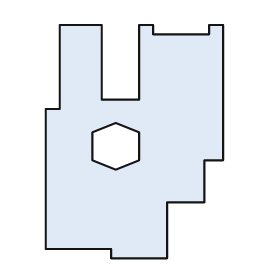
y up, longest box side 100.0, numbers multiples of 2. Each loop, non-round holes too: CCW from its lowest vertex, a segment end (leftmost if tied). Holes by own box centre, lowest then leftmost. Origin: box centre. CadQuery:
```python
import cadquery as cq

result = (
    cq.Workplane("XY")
    .moveTo(-10.0, -50.0)
    .lineTo(14.0, -50.0)
    .lineTo(14.0, -26.0)
    .lineTo(30.0, -26.0)
    .lineTo(30.0, -8.0)
    .lineTo(38.0, -8.0)
    .lineTo(38.0, 50.0)
    .lineTo(32.0, 50.0)
    .lineTo(32.0, 46.0)
    .lineTo(8.0, 46.0)
    .lineTo(8.0, 50.0)
    .lineTo(2.0, 50.0)
    .lineTo(2.0, 18.0)
    .lineTo(-14.0, 18.0)
    .lineTo(-14.0, 50.0)
    .lineTo(-32.0, 50.0)
    .lineTo(-32.0, 14.0)
    .lineTo(-38.0, 14.0)
    .lineTo(-38.0, -46.0)
    .lineTo(-10.0, -46.0)
    .close()
    .moveTo(-8.0, -12.0)
    .lineTo(2.0, -8.0)
    .lineTo(2.0, 4.0)
    .lineTo(-8.0, 8.0)
    .lineTo(-18.0, 4.0)
    .lineTo(-18.0, -8.0)
    .close()
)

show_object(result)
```